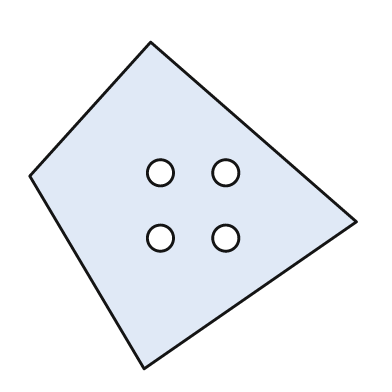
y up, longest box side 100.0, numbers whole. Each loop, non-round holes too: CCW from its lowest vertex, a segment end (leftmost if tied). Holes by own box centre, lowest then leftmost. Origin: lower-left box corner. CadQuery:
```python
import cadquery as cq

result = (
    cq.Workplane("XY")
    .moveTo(35.0, 0.0)
    .lineTo(100.0, 45.0)
    .lineTo(37.0, 100.0)
    .lineTo(0.0, 59.0)
    .close()
    .moveTo(40.0, 40.0)
    .circle(4.0)
    .moveTo(60.0, 40.0)
    .circle(4.0)
    .moveTo(40.0, 60.0)
    .circle(4.0)
    .moveTo(60.0, 60.0)
    .circle(4.0)
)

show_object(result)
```